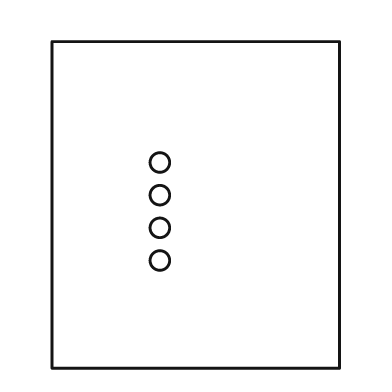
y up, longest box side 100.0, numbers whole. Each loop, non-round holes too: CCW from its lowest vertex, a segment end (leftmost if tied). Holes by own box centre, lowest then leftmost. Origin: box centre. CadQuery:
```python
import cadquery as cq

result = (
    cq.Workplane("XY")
    .moveTo(-44.0, -50.0)
    .lineTo(44.0, -50.0)
    .lineTo(44.0, 50.0)
    .lineTo(-44.0, 50.0)
    .close()
    .moveTo(-11.0, -17.0)
    .circle(3.0)
    .moveTo(-11.0, -7.0)
    .circle(3.0)
    .moveTo(-11.0, 3.0)
    .circle(3.0)
    .moveTo(-11.0, 13.0)
    .circle(3.0)
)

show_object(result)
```